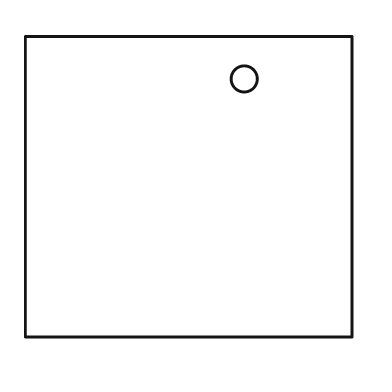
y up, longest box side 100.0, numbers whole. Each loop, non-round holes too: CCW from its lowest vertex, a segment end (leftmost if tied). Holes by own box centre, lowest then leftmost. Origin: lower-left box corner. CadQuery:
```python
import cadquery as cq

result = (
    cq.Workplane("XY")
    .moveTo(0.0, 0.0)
    .lineTo(100.0, 0.0)
    .lineTo(100.0, 92.0)
    .lineTo(0.0, 92.0)
    .close()
    .moveTo(67.0, 79.0)
    .circle(4.0)
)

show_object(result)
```